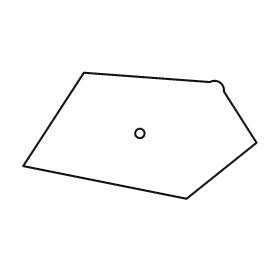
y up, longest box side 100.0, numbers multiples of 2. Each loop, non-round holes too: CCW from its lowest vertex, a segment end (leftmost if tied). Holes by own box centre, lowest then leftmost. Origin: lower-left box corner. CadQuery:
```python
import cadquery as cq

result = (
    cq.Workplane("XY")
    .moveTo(70.0, 0.0)
    .lineTo(100.0, 24.0)
    .lineTo(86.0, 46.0)
    .threePointArc((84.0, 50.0), (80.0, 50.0))
    .lineTo(26.0, 54.0)
    .lineTo(0.0, 14.0)
    .close()
    .moveTo(50.0, 28.0)
    .circle(2.0)
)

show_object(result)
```